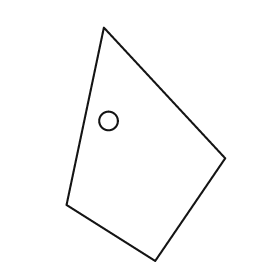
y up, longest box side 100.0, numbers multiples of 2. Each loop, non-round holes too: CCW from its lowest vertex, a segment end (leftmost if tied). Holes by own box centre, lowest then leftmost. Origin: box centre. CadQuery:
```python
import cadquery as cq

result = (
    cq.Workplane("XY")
    .moveTo(4.0, -50.0)
    .lineTo(34.0, -6.0)
    .lineTo(-18.0, 50.0)
    .lineTo(-34.0, -26.0)
    .close()
    .moveTo(-16.0, 10.0)
    .circle(4.0)
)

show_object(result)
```